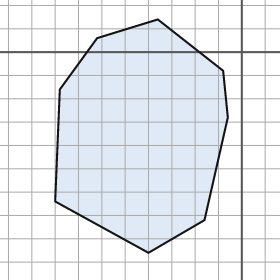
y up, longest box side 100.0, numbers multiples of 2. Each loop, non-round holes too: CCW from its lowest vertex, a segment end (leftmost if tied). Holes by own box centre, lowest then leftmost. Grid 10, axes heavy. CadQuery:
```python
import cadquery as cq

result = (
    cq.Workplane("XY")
    .moveTo(-40.0, -86.0)
    .lineTo(-16.0, -72.0)
    .lineTo(-6.0, -28.0)
    .lineTo(-8.0, -8.0)
    .lineTo(-36.0, 14.0)
    .lineTo(-62.0, 6.0)
    .lineTo(-78.0, -16.0)
    .lineTo(-80.0, -64.0)
    .close()
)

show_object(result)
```